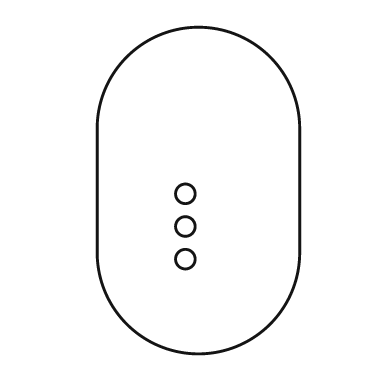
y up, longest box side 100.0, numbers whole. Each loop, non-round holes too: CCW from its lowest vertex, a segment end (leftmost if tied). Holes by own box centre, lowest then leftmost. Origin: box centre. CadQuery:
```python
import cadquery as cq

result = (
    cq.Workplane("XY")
    .moveTo(-31.0, -19.0)
    .threePointArc((0.0, -50.0), (31.0, -19.0))
    .lineTo(31.0, 19.0)
    .threePointArc((0.0, 50.0), (-31.0, 19.0))
    .close()
    .moveTo(-4.0, -21.0)
    .circle(3.0)
    .moveTo(-4.0, -11.0)
    .circle(3.0)
    .moveTo(-4.0, -1.0)
    .circle(3.0)
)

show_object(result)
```